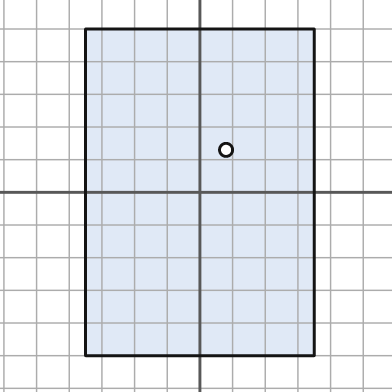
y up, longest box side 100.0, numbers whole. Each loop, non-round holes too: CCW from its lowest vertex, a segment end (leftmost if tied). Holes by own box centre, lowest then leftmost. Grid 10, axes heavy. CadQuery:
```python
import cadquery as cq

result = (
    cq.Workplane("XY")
    .moveTo(-35.0, -50.0)
    .lineTo(35.0, -50.0)
    .lineTo(35.0, 50.0)
    .lineTo(-35.0, 50.0)
    .close()
    .moveTo(8.0, 13.0)
    .circle(2.0)
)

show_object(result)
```